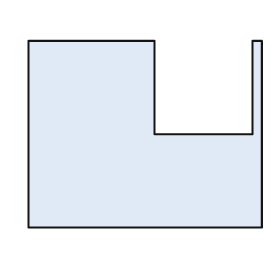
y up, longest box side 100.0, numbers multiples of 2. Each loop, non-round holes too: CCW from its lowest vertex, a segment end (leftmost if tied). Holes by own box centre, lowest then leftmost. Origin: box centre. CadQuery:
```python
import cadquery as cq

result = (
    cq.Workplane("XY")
    .moveTo(-50.0, -40.0)
    .lineTo(50.0, -40.0)
    .lineTo(50.0, 40.0)
    .lineTo(46.0, 40.0)
    .lineTo(46.0, 0.0)
    .lineTo(4.0, 0.0)
    .lineTo(4.0, 40.0)
    .lineTo(-50.0, 40.0)
    .close()
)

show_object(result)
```